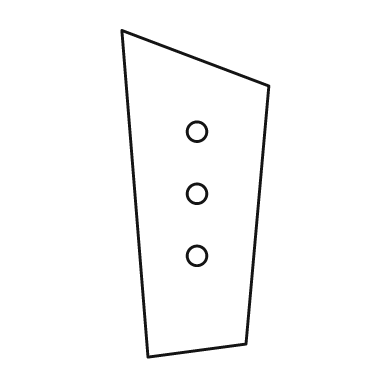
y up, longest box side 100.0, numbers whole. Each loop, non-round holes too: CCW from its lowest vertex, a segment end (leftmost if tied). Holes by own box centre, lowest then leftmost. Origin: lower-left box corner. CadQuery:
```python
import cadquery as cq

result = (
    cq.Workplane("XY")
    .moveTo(8.0, 0.0)
    .lineTo(38.0, 4.0)
    .lineTo(45.0, 83.0)
    .lineTo(0.0, 100.0)
    .close()
    .moveTo(23.0, 31.0)
    .circle(3.0)
    .moveTo(23.0, 50.0)
    .circle(3.0)
    .moveTo(23.0, 69.0)
    .circle(3.0)
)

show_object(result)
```